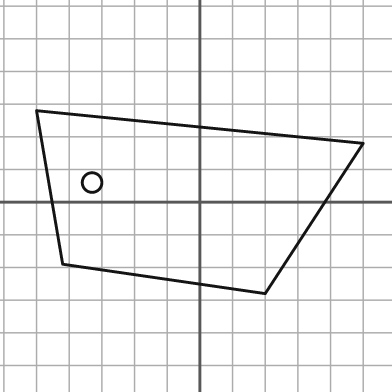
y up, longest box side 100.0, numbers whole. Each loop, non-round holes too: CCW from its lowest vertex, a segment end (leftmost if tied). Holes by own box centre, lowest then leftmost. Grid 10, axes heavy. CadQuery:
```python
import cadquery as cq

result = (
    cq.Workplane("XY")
    .moveTo(20.0, -28.0)
    .lineTo(50.0, 18.0)
    .lineTo(-50.0, 28.0)
    .lineTo(-42.0, -19.0)
    .close()
    .moveTo(-33.0, 6.0)
    .circle(3.0)
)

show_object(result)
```